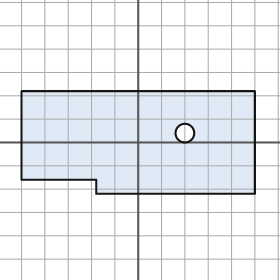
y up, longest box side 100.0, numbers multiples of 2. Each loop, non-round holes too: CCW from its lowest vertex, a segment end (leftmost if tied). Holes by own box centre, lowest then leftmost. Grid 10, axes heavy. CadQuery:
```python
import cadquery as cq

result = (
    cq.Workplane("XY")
    .moveTo(-18.0, -22.0)
    .lineTo(50.0, -22.0)
    .lineTo(50.0, 22.0)
    .lineTo(-50.0, 22.0)
    .lineTo(-50.0, -16.0)
    .lineTo(-18.0, -16.0)
    .close()
    .moveTo(20.0, 4.0)
    .circle(4.0)
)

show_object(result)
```